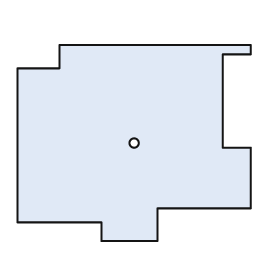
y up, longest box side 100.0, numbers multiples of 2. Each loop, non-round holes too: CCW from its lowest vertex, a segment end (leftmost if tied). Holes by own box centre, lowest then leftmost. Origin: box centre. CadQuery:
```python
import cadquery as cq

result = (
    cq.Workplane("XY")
    .moveTo(-14.0, -42.0)
    .lineTo(10.0, -42.0)
    .lineTo(10.0, -28.0)
    .lineTo(50.0, -28.0)
    .lineTo(50.0, -2.0)
    .lineTo(38.0, -2.0)
    .lineTo(38.0, 38.0)
    .lineTo(50.0, 38.0)
    .lineTo(50.0, 42.0)
    .lineTo(-32.0, 42.0)
    .lineTo(-32.0, 32.0)
    .lineTo(-50.0, 32.0)
    .lineTo(-50.0, -34.0)
    .lineTo(-14.0, -34.0)
    .close()
    .moveTo(0.0, 0.0)
    .circle(2.0)
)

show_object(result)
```